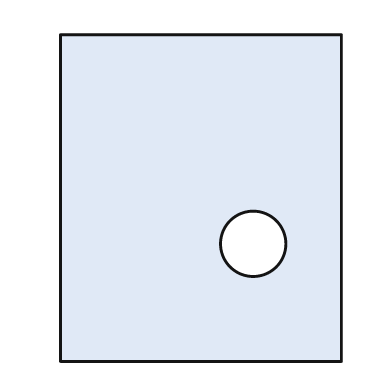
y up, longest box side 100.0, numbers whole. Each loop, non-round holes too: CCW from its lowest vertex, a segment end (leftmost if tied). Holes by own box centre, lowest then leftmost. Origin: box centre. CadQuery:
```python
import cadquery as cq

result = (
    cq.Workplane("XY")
    .moveTo(-43.0, -50.0)
    .lineTo(43.0, -50.0)
    .lineTo(43.0, 50.0)
    .lineTo(-43.0, 50.0)
    .close()
    .moveTo(16.0, -14.0)
    .circle(10.0)
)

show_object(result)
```